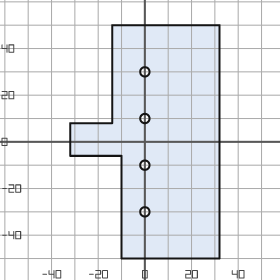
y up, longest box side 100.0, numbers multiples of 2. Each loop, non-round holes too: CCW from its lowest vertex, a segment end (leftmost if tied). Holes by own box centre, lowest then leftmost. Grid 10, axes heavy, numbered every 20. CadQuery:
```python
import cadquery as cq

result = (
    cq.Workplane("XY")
    .moveTo(-10.0, -50.0)
    .lineTo(32.0, -50.0)
    .lineTo(32.0, 50.0)
    .lineTo(-14.0, 50.0)
    .lineTo(-14.0, 8.0)
    .lineTo(-32.0, 8.0)
    .lineTo(-32.0, -6.0)
    .lineTo(-10.0, -6.0)
    .close()
    .moveTo(0.0, -30.0)
    .circle(2.0)
    .moveTo(0.0, -10.0)
    .circle(2.0)
    .moveTo(0.0, 10.0)
    .circle(2.0)
    .moveTo(0.0, 30.0)
    .circle(2.0)
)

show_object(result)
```